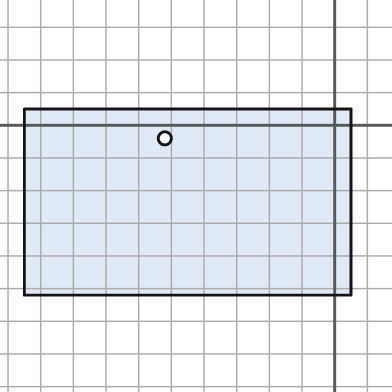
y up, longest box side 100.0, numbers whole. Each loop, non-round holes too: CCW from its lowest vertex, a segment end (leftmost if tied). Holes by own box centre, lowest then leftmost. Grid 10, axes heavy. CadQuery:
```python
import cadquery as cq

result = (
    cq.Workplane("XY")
    .moveTo(-95.0, -52.0)
    .lineTo(5.0, -52.0)
    .lineTo(5.0, 5.0)
    .lineTo(-95.0, 5.0)
    .close()
    .moveTo(-52.0, -4.0)
    .circle(2.0)
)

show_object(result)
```